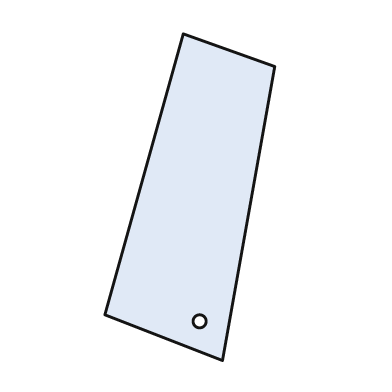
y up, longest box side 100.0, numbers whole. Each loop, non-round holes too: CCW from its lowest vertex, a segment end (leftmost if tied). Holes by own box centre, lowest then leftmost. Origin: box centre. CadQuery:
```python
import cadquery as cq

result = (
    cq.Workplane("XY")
    .moveTo(10.0, -50.0)
    .lineTo(26.0, 40.0)
    .lineTo(-2.0, 50.0)
    .lineTo(-26.0, -36.0)
    .close()
    .moveTo(3.0, -38.0)
    .circle(2.0)
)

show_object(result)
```